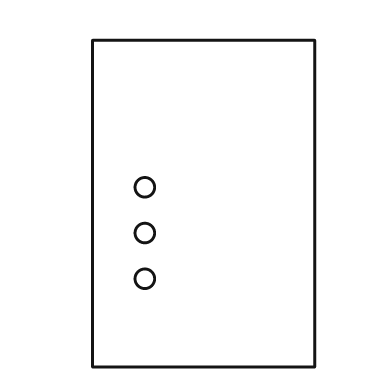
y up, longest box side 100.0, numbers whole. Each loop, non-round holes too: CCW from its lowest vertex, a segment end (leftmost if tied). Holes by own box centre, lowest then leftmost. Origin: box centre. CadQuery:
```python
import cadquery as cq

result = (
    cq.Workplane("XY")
    .moveTo(-34.0, -50.0)
    .lineTo(34.0, -50.0)
    .lineTo(34.0, 50.0)
    .lineTo(-34.0, 50.0)
    .close()
    .moveTo(-18.0, -23.0)
    .circle(3.0)
    .moveTo(-18.0, -9.0)
    .circle(3.0)
    .moveTo(-18.0, 5.0)
    .circle(3.0)
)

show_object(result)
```